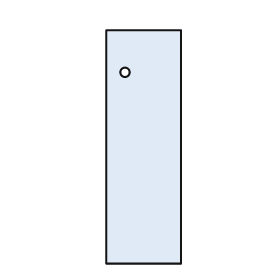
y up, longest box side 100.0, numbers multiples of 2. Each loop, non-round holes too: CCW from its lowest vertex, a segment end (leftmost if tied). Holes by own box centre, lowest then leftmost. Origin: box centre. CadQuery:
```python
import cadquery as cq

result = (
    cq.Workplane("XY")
    .moveTo(-16.0, -50.0)
    .lineTo(16.0, -50.0)
    .lineTo(16.0, 50.0)
    .lineTo(-16.0, 50.0)
    .close()
    .moveTo(-8.0, 32.0)
    .circle(2.0)
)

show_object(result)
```